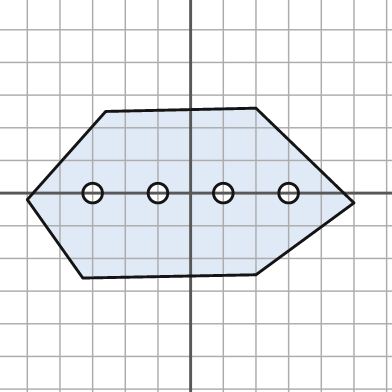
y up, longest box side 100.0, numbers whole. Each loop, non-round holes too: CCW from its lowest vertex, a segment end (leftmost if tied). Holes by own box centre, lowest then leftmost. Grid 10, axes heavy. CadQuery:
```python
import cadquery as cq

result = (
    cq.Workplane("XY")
    .moveTo(-33.0, -26.0)
    .lineTo(20.0, -25.0)
    .lineTo(50.0, -3.0)
    .lineTo(20.0, 26.0)
    .lineTo(-26.0, 25.0)
    .lineTo(-50.0, -2.0)
    .close()
    .moveTo(-30.0, 0.0)
    .circle(3.0)
    .moveTo(-10.0, 0.0)
    .circle(3.0)
    .moveTo(10.0, 0.0)
    .circle(3.0)
    .moveTo(30.0, 0.0)
    .circle(3.0)
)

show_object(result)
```